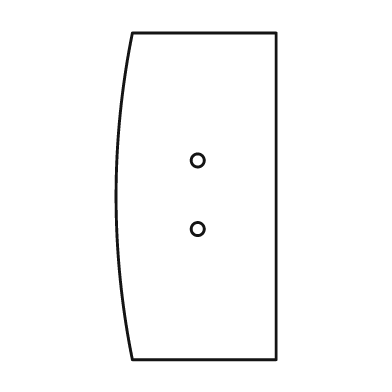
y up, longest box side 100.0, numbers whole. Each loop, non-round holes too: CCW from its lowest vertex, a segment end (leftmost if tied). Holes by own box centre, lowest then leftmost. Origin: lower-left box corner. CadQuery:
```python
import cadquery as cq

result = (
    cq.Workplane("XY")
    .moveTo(5.0, 0.0)
    .lineTo(49.0, 0.0)
    .lineTo(49.0, 100.0)
    .lineTo(5.0, 100.0)
    .threePointArc((0.0, 50.0), (5.0, 0.0))
    .close()
    .moveTo(25.0, 40.0)
    .circle(2.0)
    .moveTo(25.0, 61.0)
    .circle(2.0)
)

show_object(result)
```